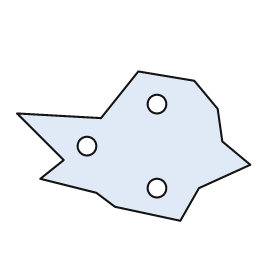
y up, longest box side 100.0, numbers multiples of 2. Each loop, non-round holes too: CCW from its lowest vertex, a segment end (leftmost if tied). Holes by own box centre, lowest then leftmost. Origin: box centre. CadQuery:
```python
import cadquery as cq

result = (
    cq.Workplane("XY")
    .moveTo(20.0, -32.0)
    .lineTo(28.0, -18.0)
    .lineTo(50.0, -8.0)
    .lineTo(38.0, 2.0)
    .lineTo(36.0, 16.0)
    .lineTo(26.0, 28.0)
    .lineTo(2.0, 32.0)
    .lineTo(-14.0, 12.0)
    .lineTo(-50.0, 14.0)
    .lineTo(-30.0, -6.0)
    .lineTo(-40.0, -14.0)
    .lineTo(-16.0, -20.0)
    .lineTo(-8.0, -26.0)
    .close()
    .moveTo(10.0, -18.0)
    .circle(4.0)
    .moveTo(-20.0, 0.0)
    .circle(4.0)
    .moveTo(10.0, 18.0)
    .circle(4.0)
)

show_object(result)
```